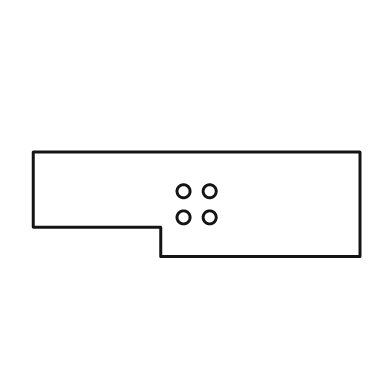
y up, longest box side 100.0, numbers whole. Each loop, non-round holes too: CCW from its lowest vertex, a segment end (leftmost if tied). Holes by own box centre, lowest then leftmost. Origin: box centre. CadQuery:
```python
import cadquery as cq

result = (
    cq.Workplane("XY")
    .moveTo(-11.0, -16.0)
    .lineTo(50.0, -16.0)
    .lineTo(50.0, 16.0)
    .lineTo(-50.0, 16.0)
    .lineTo(-50.0, -7.0)
    .lineTo(-11.0, -7.0)
    .close()
    .moveTo(-4.0, -4.0)
    .circle(2.0)
    .moveTo(4.0, -4.0)
    .circle(2.0)
    .moveTo(-4.0, 4.0)
    .circle(2.0)
    .moveTo(4.0, 4.0)
    .circle(2.0)
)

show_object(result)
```